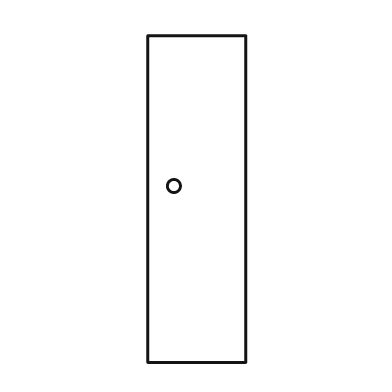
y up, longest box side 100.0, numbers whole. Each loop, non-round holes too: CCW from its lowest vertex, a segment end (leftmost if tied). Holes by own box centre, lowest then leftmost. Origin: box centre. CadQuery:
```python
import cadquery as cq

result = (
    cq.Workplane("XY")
    .moveTo(-15.0, -50.0)
    .lineTo(15.0, -50.0)
    .lineTo(15.0, 50.0)
    .lineTo(-15.0, 50.0)
    .close()
    .moveTo(-7.0, 4.0)
    .circle(2.0)
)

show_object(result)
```